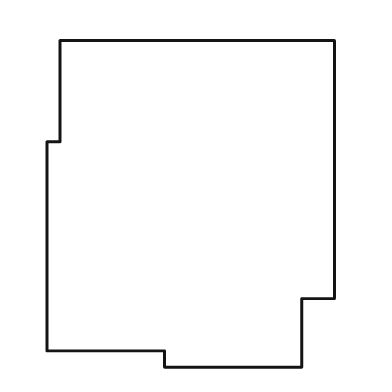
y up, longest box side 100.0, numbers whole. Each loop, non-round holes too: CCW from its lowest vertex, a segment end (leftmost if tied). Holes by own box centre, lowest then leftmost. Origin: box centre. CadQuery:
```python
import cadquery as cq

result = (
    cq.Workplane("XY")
    .moveTo(-8.0, -50.0)
    .lineTo(34.0, -50.0)
    .lineTo(34.0, -29.0)
    .lineTo(44.0, -29.0)
    .lineTo(44.0, 50.0)
    .lineTo(-40.0, 50.0)
    .lineTo(-40.0, 19.0)
    .lineTo(-44.0, 19.0)
    .lineTo(-44.0, -45.0)
    .lineTo(-8.0, -45.0)
    .close()
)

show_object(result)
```